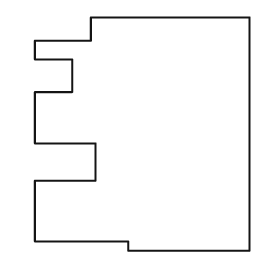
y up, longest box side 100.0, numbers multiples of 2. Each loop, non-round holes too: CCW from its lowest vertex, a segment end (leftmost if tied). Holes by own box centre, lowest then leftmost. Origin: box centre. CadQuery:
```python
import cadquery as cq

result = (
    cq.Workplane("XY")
    .moveTo(-6.0, -50.0)
    .lineTo(46.0, -50.0)
    .lineTo(46.0, 50.0)
    .lineTo(-22.0, 50.0)
    .lineTo(-22.0, 40.0)
    .lineTo(-46.0, 40.0)
    .lineTo(-46.0, 32.0)
    .lineTo(-30.0, 32.0)
    .lineTo(-30.0, 18.0)
    .lineTo(-46.0, 18.0)
    .lineTo(-46.0, -4.0)
    .lineTo(-20.0, -4.0)
    .lineTo(-20.0, -20.0)
    .lineTo(-46.0, -20.0)
    .lineTo(-46.0, -46.0)
    .lineTo(-6.0, -46.0)
    .close()
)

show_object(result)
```